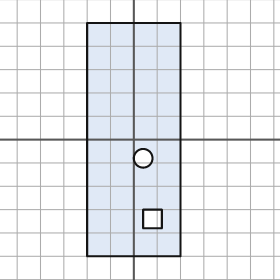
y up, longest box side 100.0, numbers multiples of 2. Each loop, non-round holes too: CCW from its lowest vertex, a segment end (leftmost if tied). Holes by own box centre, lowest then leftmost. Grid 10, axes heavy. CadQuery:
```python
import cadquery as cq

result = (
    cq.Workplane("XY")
    .moveTo(-20.0, -50.0)
    .lineTo(20.0, -50.0)
    .lineTo(20.0, 50.0)
    .lineTo(-20.0, 50.0)
    .close()
    .moveTo(4.0, -38.0)
    .lineTo(12.0, -38.0)
    .lineTo(12.0, -30.0)
    .lineTo(4.0, -30.0)
    .close()
    .moveTo(4.0, -8.0)
    .circle(4.0)
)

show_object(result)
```